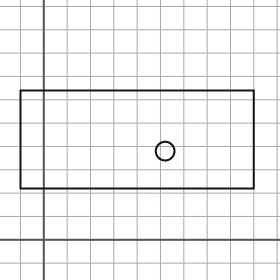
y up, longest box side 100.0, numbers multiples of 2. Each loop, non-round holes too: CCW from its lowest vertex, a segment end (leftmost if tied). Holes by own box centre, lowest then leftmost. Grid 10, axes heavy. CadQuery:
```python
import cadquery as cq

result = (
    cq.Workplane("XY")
    .moveTo(-10.0, 22.0)
    .lineTo(90.0, 22.0)
    .lineTo(90.0, 64.0)
    .lineTo(-10.0, 64.0)
    .close()
    .moveTo(52.0, 38.0)
    .circle(4.0)
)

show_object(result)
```